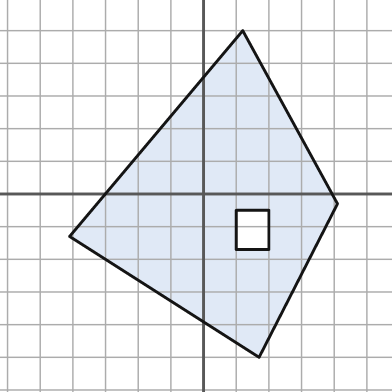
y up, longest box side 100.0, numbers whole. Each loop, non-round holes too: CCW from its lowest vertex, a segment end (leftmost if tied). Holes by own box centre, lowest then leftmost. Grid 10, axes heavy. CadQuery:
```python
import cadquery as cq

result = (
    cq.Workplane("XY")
    .moveTo(17.0, -50.0)
    .lineTo(41.0, -3.0)
    .lineTo(12.0, 50.0)
    .lineTo(-41.0, -13.0)
    .close()
    .moveTo(10.0, -17.0)
    .lineTo(20.0, -17.0)
    .lineTo(20.0, -5.0)
    .lineTo(10.0, -5.0)
    .close()
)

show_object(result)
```